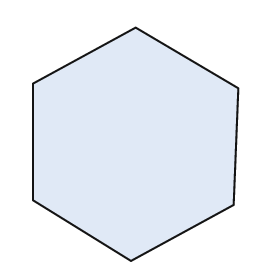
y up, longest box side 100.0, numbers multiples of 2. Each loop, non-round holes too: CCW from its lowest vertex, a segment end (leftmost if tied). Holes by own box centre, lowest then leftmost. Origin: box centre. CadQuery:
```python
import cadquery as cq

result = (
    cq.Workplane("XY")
    .moveTo(-2.0, -50.0)
    .lineTo(42.0, -26.0)
    .lineTo(44.0, 24.0)
    .lineTo(0.0, 50.0)
    .lineTo(-44.0, 26.0)
    .lineTo(-44.0, -24.0)
    .close()
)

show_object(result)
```